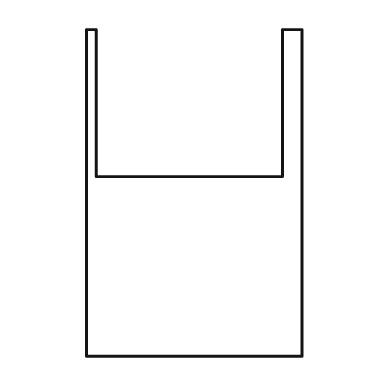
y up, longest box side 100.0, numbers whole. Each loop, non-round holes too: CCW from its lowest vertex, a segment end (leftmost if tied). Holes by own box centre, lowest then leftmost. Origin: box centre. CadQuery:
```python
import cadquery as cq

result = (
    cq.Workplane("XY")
    .moveTo(-33.0, -50.0)
    .lineTo(33.0, -50.0)
    .lineTo(33.0, 50.0)
    .lineTo(27.0, 50.0)
    .lineTo(27.0, 5.0)
    .lineTo(-30.0, 5.0)
    .lineTo(-30.0, 50.0)
    .lineTo(-33.0, 50.0)
    .close()
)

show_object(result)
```